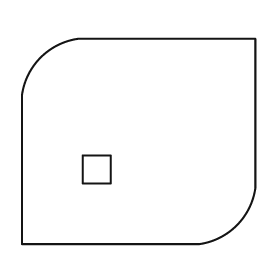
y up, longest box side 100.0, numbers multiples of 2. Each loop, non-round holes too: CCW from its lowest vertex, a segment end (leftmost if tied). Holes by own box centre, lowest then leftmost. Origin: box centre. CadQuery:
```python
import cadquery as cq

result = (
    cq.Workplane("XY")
    .moveTo(-50.0, -44.0)
    .lineTo(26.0, -44.0)
    .threePointArc((42.0, -36.0), (50.0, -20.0))
    .lineTo(50.0, 44.0)
    .lineTo(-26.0, 44.0)
    .threePointArc((-42.0, 36.0), (-50.0, 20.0))
    .close()
    .moveTo(-24.0, -18.0)
    .lineTo(-12.0, -18.0)
    .lineTo(-12.0, -6.0)
    .lineTo(-24.0, -6.0)
    .close()
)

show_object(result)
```